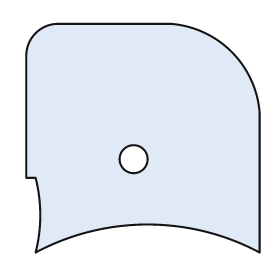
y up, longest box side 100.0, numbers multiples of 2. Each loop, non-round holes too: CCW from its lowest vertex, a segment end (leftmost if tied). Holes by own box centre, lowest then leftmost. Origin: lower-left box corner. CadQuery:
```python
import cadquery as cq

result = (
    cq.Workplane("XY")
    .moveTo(4.0, 0.0)
    .threePointArc((52.0, 12.0), (100.0, 0.0))
    .lineTo(100.0, 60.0)
    .threePointArc((88.0, 86.0), (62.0, 98.0))
    .lineTo(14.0, 98.0)
    .threePointArc((4.0, 94.0), (0.0, 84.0))
    .lineTo(0.0, 32.0)
    .lineTo(4.0, 32.0)
    .threePointArc((6.0, 16.0), (4.0, 0.0))
    .close()
    .moveTo(46.0, 40.0)
    .circle(6.0)
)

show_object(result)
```